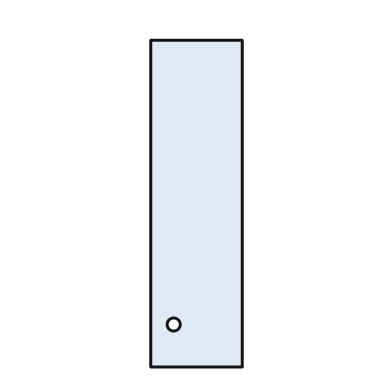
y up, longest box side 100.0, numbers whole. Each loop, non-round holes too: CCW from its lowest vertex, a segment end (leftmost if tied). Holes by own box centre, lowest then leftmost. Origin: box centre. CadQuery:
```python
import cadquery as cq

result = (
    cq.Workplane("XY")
    .moveTo(-14.0, -50.0)
    .lineTo(14.0, -50.0)
    .lineTo(14.0, 50.0)
    .lineTo(-14.0, 50.0)
    .close()
    .moveTo(-7.0, -37.0)
    .circle(2.0)
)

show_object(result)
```